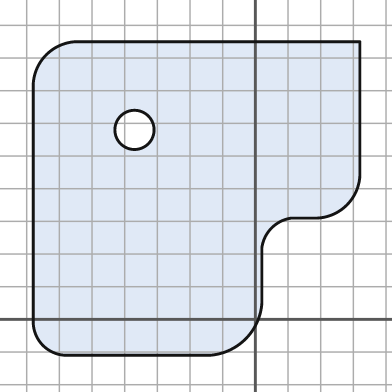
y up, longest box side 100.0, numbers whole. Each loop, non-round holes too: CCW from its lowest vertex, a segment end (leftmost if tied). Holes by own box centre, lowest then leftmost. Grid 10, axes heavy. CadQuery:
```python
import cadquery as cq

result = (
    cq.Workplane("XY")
    .moveTo(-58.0, -11.0)
    .lineTo(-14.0, -11.0)
    .threePointArc((-3.0, -6.0), (2.0, 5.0))
    .lineTo(2.0, 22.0)
    .threePointArc((5.0, 28.0), (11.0, 31.0))
    .lineTo(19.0, 31.0)
    .threePointArc((28.0, 35.0), (32.0, 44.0))
    .lineTo(32.0, 85.0)
    .lineTo(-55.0, 85.0)
    .threePointArc((-64.0, 81.0), (-68.0, 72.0))
    .lineTo(-68.0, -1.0)
    .threePointArc((-65.0, -8.0), (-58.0, -11.0))
    .close()
    .moveTo(-37.0, 58.0)
    .circle(6.0)
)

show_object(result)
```